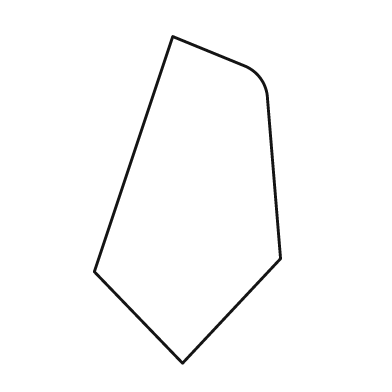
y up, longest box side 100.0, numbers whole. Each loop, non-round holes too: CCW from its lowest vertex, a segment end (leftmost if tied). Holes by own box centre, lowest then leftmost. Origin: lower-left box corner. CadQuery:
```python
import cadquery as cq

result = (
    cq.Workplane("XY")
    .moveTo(27.0, 0.0)
    .lineTo(57.0, 32.0)
    .lineTo(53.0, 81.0)
    .threePointArc((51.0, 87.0), (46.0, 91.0))
    .lineTo(24.0, 100.0)
    .lineTo(0.0, 28.0)
    .close()
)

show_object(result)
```